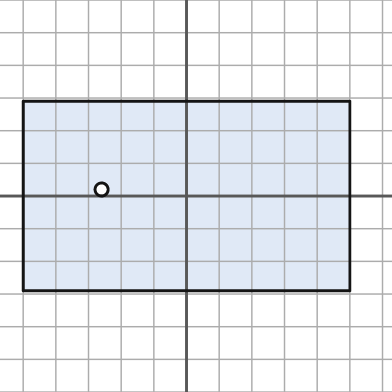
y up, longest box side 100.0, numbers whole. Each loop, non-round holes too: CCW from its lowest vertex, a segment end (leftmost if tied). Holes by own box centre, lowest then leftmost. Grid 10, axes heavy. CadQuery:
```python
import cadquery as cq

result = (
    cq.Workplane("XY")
    .moveTo(-50.0, -29.0)
    .lineTo(50.0, -29.0)
    .lineTo(50.0, 29.0)
    .lineTo(-50.0, 29.0)
    .close()
    .moveTo(-26.0, 2.0)
    .circle(2.0)
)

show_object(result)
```